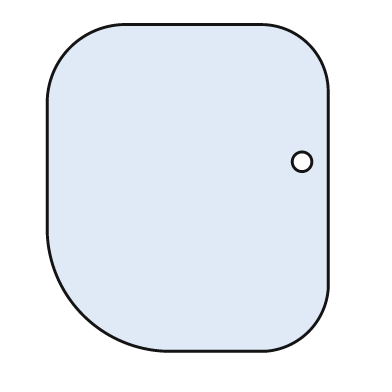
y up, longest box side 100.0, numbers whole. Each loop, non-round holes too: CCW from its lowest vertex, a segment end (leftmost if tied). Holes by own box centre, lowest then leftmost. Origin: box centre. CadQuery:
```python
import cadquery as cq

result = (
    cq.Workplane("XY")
    .moveTo(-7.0, -50.0)
    .lineTo(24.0, -50.0)
    .threePointArc((37.0, -44.0), (43.0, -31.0))
    .lineTo(43.0, 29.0)
    .threePointArc((37.0, 44.0), (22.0, 50.0))
    .lineTo(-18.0, 50.0)
    .threePointArc((-36.0, 43.0), (-43.0, 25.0))
    .lineTo(-43.0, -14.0)
    .threePointArc((-32.0, -39.0), (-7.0, -50.0))
    .close()
    .moveTo(35.0, 8.0)
    .circle(3.0)
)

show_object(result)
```